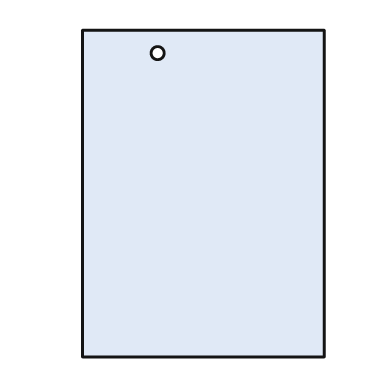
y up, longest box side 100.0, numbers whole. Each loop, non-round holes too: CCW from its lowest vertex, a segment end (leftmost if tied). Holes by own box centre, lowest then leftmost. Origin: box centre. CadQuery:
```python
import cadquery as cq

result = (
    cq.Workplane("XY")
    .moveTo(-37.0, -50.0)
    .lineTo(37.0, -50.0)
    .lineTo(37.0, 50.0)
    .lineTo(-37.0, 50.0)
    .close()
    .moveTo(-14.0, 43.0)
    .circle(2.0)
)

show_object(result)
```